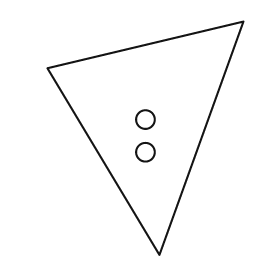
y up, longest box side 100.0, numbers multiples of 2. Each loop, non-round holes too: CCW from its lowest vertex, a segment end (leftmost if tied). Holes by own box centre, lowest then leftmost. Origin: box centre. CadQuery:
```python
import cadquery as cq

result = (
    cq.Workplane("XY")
    .moveTo(6.0, -50.0)
    .lineTo(42.0, 50.0)
    .lineTo(-42.0, 30.0)
    .close()
    .moveTo(0.0, -6.0)
    .circle(4.0)
    .moveTo(0.0, 8.0)
    .circle(4.0)
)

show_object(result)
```